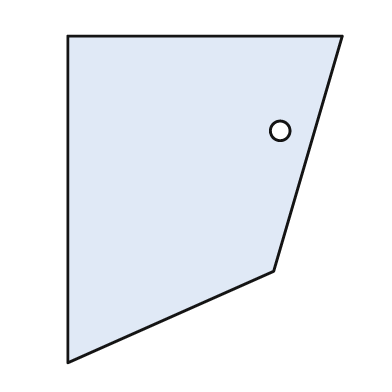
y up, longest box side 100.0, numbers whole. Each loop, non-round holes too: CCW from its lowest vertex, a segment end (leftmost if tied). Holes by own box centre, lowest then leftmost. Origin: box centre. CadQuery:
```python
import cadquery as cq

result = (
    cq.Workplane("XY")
    .moveTo(-42.0, -50.0)
    .lineTo(21.0, -22.0)
    .lineTo(42.0, 50.0)
    .lineTo(-42.0, 50.0)
    .close()
    .moveTo(23.0, 21.0)
    .circle(3.0)
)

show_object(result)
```